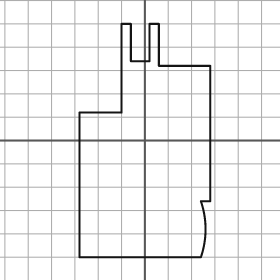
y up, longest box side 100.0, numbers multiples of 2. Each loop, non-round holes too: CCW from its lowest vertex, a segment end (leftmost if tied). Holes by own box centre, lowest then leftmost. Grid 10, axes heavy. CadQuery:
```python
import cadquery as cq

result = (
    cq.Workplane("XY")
    .moveTo(-28.0, -50.0)
    .lineTo(24.0, -50.0)
    .threePointArc((26.0, -38.0), (24.0, -26.0))
    .lineTo(28.0, -26.0)
    .lineTo(28.0, 32.0)
    .lineTo(6.0, 32.0)
    .lineTo(6.0, 50.0)
    .lineTo(2.0, 50.0)
    .lineTo(2.0, 34.0)
    .lineTo(-6.0, 34.0)
    .lineTo(-6.0, 50.0)
    .lineTo(-10.0, 50.0)
    .lineTo(-10.0, 12.0)
    .lineTo(-28.0, 12.0)
    .close()
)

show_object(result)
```